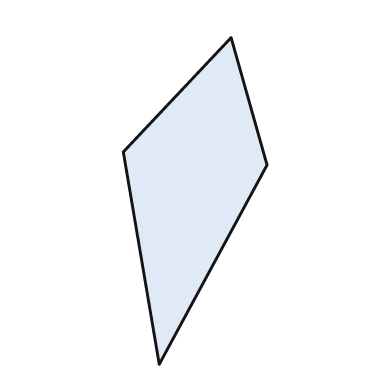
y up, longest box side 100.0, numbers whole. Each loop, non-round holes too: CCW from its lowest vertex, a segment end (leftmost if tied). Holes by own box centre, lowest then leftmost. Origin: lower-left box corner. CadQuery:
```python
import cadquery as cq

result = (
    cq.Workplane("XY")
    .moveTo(11.0, 0.0)
    .lineTo(44.0, 61.0)
    .lineTo(33.0, 100.0)
    .lineTo(0.0, 65.0)
    .close()
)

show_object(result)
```